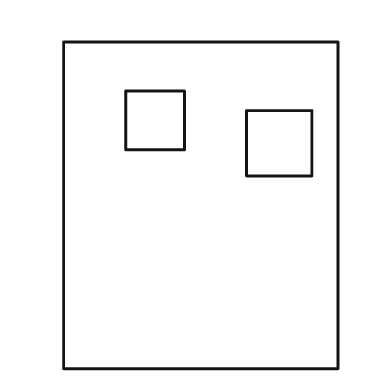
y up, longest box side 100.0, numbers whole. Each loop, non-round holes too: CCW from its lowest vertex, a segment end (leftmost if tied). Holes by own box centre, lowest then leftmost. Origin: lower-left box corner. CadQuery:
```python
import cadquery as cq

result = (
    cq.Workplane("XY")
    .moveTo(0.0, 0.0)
    .lineTo(84.0, 0.0)
    .lineTo(84.0, 100.0)
    .lineTo(0.0, 100.0)
    .close()
    .moveTo(56.0, 59.0)
    .lineTo(76.0, 59.0)
    .lineTo(76.0, 79.0)
    .lineTo(56.0, 79.0)
    .close()
    .moveTo(19.0, 67.0)
    .lineTo(37.0, 67.0)
    .lineTo(37.0, 85.0)
    .lineTo(19.0, 85.0)
    .close()
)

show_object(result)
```